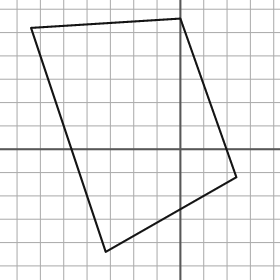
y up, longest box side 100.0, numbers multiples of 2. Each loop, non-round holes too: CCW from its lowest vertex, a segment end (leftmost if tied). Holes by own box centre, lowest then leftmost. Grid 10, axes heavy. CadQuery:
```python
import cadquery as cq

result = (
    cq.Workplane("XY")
    .moveTo(-32.0, -44.0)
    .lineTo(24.0, -12.0)
    .lineTo(0.0, 56.0)
    .lineTo(-64.0, 52.0)
    .close()
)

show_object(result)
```